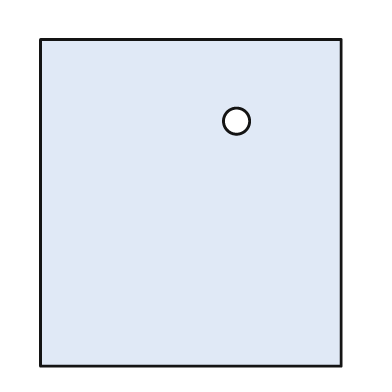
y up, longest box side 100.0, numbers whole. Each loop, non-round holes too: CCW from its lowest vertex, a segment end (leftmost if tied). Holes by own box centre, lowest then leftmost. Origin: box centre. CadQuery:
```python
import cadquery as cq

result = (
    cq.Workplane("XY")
    .moveTo(-46.0, -50.0)
    .lineTo(46.0, -50.0)
    .lineTo(46.0, 50.0)
    .lineTo(-46.0, 50.0)
    .close()
    .moveTo(14.0, 25.0)
    .circle(4.0)
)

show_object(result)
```